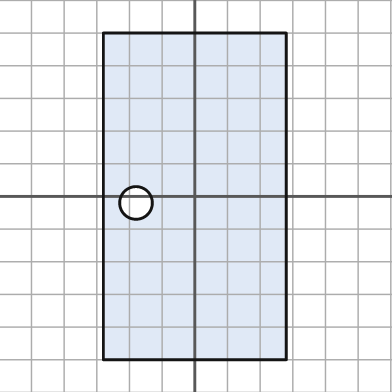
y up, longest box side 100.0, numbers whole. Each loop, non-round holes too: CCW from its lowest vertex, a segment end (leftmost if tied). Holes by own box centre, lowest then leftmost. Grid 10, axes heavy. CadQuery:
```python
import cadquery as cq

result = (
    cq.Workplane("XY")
    .moveTo(-28.0, -50.0)
    .lineTo(28.0, -50.0)
    .lineTo(28.0, 50.0)
    .lineTo(-28.0, 50.0)
    .close()
    .moveTo(-18.0, -2.0)
    .circle(5.0)
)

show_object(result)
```